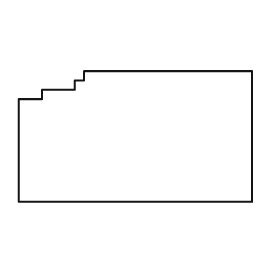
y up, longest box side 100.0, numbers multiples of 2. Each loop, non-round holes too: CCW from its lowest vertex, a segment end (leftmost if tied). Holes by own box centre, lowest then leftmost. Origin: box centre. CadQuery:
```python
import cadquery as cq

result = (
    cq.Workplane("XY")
    .moveTo(-50.0, -28.0)
    .lineTo(50.0, -28.0)
    .lineTo(50.0, 28.0)
    .lineTo(-22.0, 28.0)
    .lineTo(-22.0, 24.0)
    .lineTo(-26.0, 24.0)
    .lineTo(-26.0, 20.0)
    .lineTo(-40.0, 20.0)
    .lineTo(-40.0, 16.0)
    .lineTo(-50.0, 16.0)
    .close()
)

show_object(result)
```